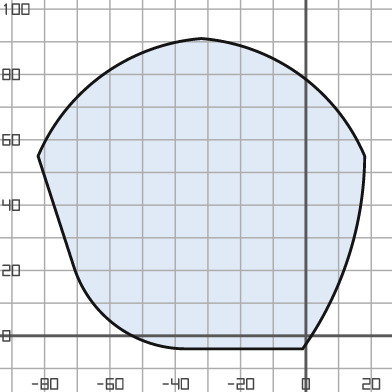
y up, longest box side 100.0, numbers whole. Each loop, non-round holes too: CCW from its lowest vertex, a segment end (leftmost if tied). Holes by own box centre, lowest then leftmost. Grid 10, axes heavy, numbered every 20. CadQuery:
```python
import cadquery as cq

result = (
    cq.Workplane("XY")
    .moveTo(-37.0, -4.0)
    .lineTo(-1.0, -4.0)
    .threePointArc((13.0, 24.0), (18.0, 55.0))
    .threePointArc((-2.0, 80.0), (-32.0, 91.0))
    .threePointArc((-62.0, 80.0), (-82.0, 55.0))
    .lineTo(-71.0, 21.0)
    .threePointArc((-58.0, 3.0), (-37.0, -4.0))
    .close()
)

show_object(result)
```